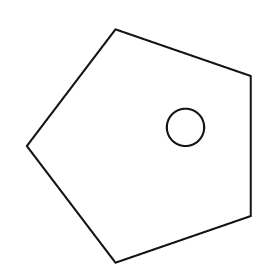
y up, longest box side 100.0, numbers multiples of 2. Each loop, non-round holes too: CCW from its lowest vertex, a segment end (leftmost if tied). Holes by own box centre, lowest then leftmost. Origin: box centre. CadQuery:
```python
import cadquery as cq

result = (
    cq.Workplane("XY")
    .moveTo(-10.0, -50.0)
    .lineTo(48.0, -30.0)
    .lineTo(48.0, 30.0)
    .lineTo(-10.0, 50.0)
    .lineTo(-48.0, 0.0)
    .close()
    .moveTo(20.0, 8.0)
    .circle(8.0)
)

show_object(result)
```